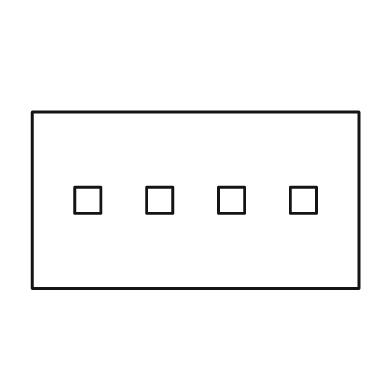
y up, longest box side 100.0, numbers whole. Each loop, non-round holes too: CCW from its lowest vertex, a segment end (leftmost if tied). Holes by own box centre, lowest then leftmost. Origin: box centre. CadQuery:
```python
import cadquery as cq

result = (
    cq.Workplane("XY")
    .moveTo(-50.0, -27.0)
    .lineTo(50.0, -27.0)
    .lineTo(50.0, 27.0)
    .lineTo(-50.0, 27.0)
    .close()
    .moveTo(-37.0, -4.0)
    .lineTo(-29.0, -4.0)
    .lineTo(-29.0, 4.0)
    .lineTo(-37.0, 4.0)
    .close()
    .moveTo(-15.0, -4.0)
    .lineTo(-7.0, -4.0)
    .lineTo(-7.0, 4.0)
    .lineTo(-15.0, 4.0)
    .close()
    .moveTo(7.0, -4.0)
    .lineTo(15.0, -4.0)
    .lineTo(15.0, 4.0)
    .lineTo(7.0, 4.0)
    .close()
    .moveTo(29.0, -4.0)
    .lineTo(37.0, -4.0)
    .lineTo(37.0, 4.0)
    .lineTo(29.0, 4.0)
    .close()
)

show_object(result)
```